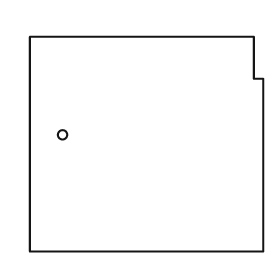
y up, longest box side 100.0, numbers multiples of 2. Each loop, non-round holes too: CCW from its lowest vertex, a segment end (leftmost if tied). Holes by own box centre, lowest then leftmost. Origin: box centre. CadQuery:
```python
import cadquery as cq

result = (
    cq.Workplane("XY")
    .moveTo(-50.0, -46.0)
    .lineTo(50.0, -46.0)
    .lineTo(50.0, 28.0)
    .lineTo(46.0, 28.0)
    .lineTo(46.0, 46.0)
    .lineTo(-50.0, 46.0)
    .close()
    .moveTo(-36.0, 4.0)
    .circle(2.0)
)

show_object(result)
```